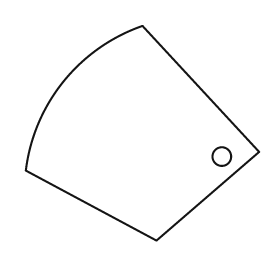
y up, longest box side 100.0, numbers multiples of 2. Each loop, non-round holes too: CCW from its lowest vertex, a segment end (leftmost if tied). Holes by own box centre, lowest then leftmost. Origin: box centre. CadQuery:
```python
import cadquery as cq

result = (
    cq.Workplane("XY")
    .moveTo(6.0, -46.0)
    .lineTo(50.0, -8.0)
    .lineTo(0.0, 46.0)
    .threePointArc((-34.0, 22.0), (-50.0, -16.0))
    .close()
    .moveTo(34.0, -10.0)
    .circle(4.0)
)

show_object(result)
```